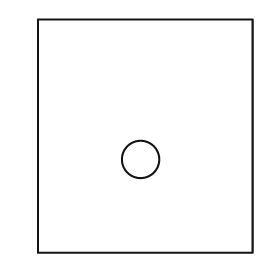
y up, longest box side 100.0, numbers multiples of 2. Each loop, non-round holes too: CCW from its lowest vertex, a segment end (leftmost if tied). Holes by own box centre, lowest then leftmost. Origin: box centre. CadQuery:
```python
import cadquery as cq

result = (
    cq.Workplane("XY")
    .moveTo(-46.0, -50.0)
    .lineTo(46.0, -50.0)
    .lineTo(46.0, 50.0)
    .lineTo(-46.0, 50.0)
    .close()
    .moveTo(-2.0, -10.0)
    .circle(8.0)
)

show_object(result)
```